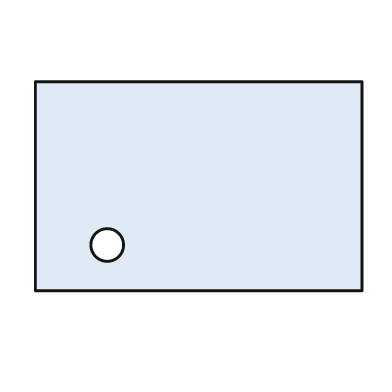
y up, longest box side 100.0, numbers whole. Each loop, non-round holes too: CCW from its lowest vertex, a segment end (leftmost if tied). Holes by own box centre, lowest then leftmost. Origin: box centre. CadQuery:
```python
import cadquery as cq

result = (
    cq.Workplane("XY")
    .moveTo(-50.0, -32.0)
    .lineTo(50.0, -32.0)
    .lineTo(50.0, 32.0)
    .lineTo(-50.0, 32.0)
    .close()
    .moveTo(-28.0, -18.0)
    .circle(5.0)
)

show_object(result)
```